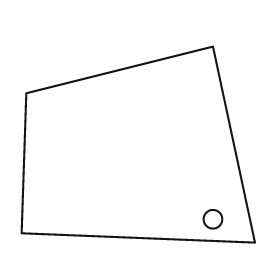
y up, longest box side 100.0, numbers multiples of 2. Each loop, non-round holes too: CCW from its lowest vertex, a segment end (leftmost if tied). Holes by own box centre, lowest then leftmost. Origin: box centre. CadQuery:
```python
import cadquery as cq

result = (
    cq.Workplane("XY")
    .moveTo(50.0, -42.0)
    .lineTo(32.0, 42.0)
    .lineTo(-48.0, 22.0)
    .lineTo(-50.0, -38.0)
    .close()
    .moveTo(32.0, -32.0)
    .circle(4.0)
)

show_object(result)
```